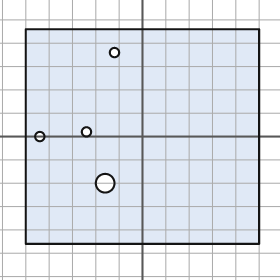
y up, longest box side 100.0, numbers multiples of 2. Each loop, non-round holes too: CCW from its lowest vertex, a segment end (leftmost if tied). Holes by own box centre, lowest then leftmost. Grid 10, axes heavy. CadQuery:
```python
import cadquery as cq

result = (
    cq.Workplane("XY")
    .moveTo(-50.0, -46.0)
    .lineTo(50.0, -46.0)
    .lineTo(50.0, 46.0)
    .lineTo(-50.0, 46.0)
    .close()
    .moveTo(-16.0, -20.0)
    .circle(4.0)
    .moveTo(-44.0, 0.0)
    .circle(2.0)
    .moveTo(-24.0, 2.0)
    .circle(2.0)
    .moveTo(-12.0, 36.0)
    .circle(2.0)
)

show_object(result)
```